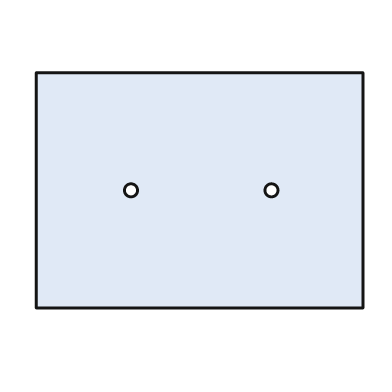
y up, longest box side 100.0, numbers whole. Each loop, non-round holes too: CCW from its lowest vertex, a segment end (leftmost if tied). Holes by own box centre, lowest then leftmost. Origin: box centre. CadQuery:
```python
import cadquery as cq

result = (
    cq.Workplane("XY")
    .moveTo(-50.0, -36.0)
    .lineTo(50.0, -36.0)
    .lineTo(50.0, 36.0)
    .lineTo(-50.0, 36.0)
    .close()
    .moveTo(-21.0, 0.0)
    .circle(2.0)
    .moveTo(22.0, 0.0)
    .circle(2.0)
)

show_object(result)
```